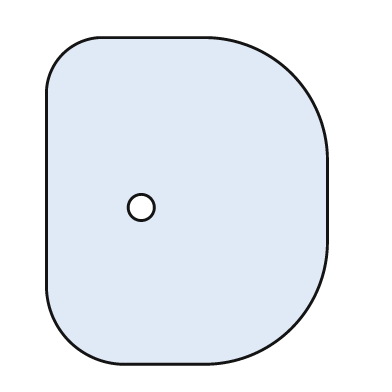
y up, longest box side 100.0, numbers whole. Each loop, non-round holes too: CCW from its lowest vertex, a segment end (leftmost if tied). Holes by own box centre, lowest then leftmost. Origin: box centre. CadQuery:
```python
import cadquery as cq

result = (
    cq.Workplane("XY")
    .moveTo(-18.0, -50.0)
    .lineTo(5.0, -50.0)
    .threePointArc((32.0, -39.0), (43.0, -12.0))
    .lineTo(43.0, 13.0)
    .threePointArc((32.0, 39.0), (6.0, 50.0))
    .lineTo(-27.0, 50.0)
    .threePointArc((-38.0, 45.0), (-43.0, 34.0))
    .lineTo(-43.0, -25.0)
    .threePointArc((-36.0, -43.0), (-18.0, -50.0))
    .close()
    .moveTo(-14.0, -2.0)
    .circle(4.0)
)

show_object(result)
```